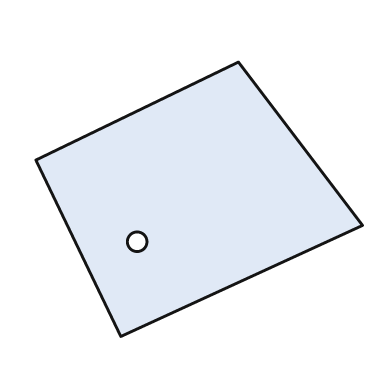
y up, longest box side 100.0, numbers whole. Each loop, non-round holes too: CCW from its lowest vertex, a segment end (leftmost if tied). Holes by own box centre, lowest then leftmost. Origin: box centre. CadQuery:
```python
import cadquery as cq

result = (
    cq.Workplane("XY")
    .moveTo(-24.0, -42.0)
    .lineTo(50.0, -8.0)
    .lineTo(12.0, 42.0)
    .lineTo(-50.0, 12.0)
    .close()
    .moveTo(-19.0, -13.0)
    .circle(3.0)
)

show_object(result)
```